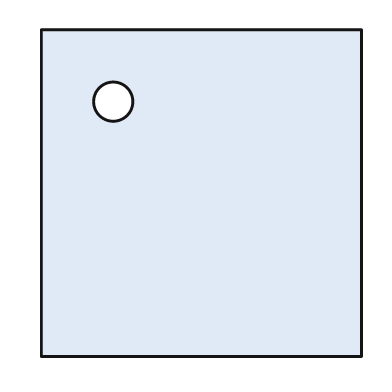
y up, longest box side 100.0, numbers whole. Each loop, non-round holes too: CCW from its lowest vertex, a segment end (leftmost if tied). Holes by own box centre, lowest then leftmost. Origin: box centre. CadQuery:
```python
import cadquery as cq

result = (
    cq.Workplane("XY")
    .moveTo(-49.0, -50.0)
    .lineTo(49.0, -50.0)
    .lineTo(49.0, 50.0)
    .lineTo(-49.0, 50.0)
    .close()
    .moveTo(-27.0, 28.0)
    .circle(6.0)
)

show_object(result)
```